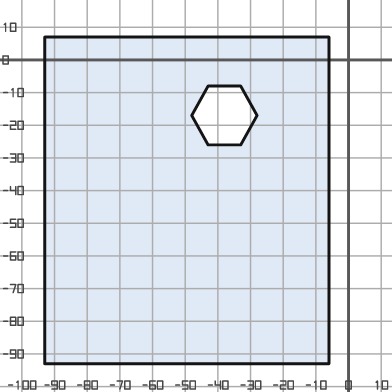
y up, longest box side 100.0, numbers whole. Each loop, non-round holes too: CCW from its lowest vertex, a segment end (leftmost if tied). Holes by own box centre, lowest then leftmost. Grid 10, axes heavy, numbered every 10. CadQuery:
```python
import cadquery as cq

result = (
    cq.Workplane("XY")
    .moveTo(-93.0, -93.0)
    .lineTo(-6.0, -93.0)
    .lineTo(-6.0, 7.0)
    .lineTo(-93.0, 7.0)
    .close()
    .moveTo(-43.0, -26.0)
    .lineTo(-33.0, -26.0)
    .lineTo(-28.0, -17.0)
    .lineTo(-33.0, -8.0)
    .lineTo(-43.0, -8.0)
    .lineTo(-48.0, -17.0)
    .close()
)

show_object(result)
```